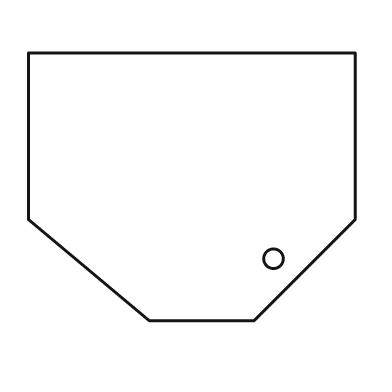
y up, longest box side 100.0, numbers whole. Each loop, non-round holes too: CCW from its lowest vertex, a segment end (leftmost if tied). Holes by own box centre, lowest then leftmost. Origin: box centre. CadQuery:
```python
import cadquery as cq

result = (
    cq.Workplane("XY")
    .moveTo(-13.0, -41.0)
    .lineTo(19.0, -41.0)
    .lineTo(50.0, -10.0)
    .lineTo(50.0, 41.0)
    .lineTo(-50.0, 41.0)
    .lineTo(-50.0, -10.0)
    .close()
    .moveTo(25.0, -22.0)
    .circle(3.0)
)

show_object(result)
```